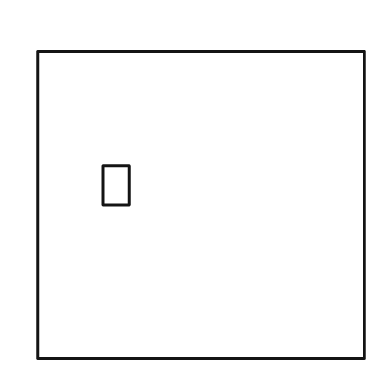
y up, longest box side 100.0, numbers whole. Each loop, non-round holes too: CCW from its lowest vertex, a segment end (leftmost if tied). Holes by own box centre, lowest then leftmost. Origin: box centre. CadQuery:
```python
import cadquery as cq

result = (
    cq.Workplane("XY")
    .moveTo(-50.0, -47.0)
    .lineTo(50.0, -47.0)
    .lineTo(50.0, 47.0)
    .lineTo(-50.0, 47.0)
    .close()
    .moveTo(-30.0, 0.0)
    .lineTo(-22.0, 0.0)
    .lineTo(-22.0, 12.0)
    .lineTo(-30.0, 12.0)
    .close()
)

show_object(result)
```